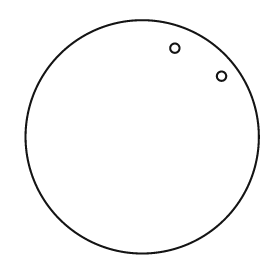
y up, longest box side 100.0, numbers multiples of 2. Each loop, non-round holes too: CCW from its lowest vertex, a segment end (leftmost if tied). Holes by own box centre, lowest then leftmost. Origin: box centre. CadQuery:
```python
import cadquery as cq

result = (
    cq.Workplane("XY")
    .moveTo(0.0, 0.0)
    .circle(50.0)
    .moveTo(34.0, 26.0)
    .circle(2.0)
    .moveTo(14.0, 38.0)
    .circle(2.0)
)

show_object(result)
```